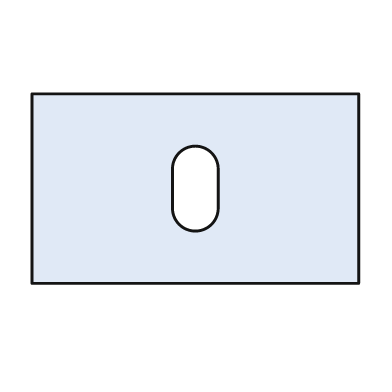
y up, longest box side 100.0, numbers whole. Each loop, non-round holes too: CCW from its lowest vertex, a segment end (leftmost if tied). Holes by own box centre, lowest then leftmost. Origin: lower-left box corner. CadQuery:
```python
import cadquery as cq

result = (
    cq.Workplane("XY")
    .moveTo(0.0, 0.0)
    .lineTo(100.0, 0.0)
    .lineTo(100.0, 58.0)
    .lineTo(0.0, 58.0)
    .close()
    .moveTo(43.0, 23.0)
    .threePointArc((50.0, 16.0), (57.0, 23.0))
    .lineTo(57.0, 35.0)
    .threePointArc((50.0, 42.0), (43.0, 35.0))
    .close()
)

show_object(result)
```